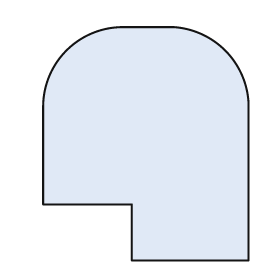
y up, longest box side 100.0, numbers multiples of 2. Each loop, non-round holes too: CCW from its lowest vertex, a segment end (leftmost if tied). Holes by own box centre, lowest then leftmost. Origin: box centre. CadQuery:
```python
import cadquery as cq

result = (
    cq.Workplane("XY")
    .moveTo(-6.0, -50.0)
    .lineTo(44.0, -50.0)
    .lineTo(44.0, 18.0)
    .threePointArc((34.0, 40.0), (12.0, 50.0))
    .lineTo(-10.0, 50.0)
    .threePointArc((-34.0, 40.0), (-44.0, 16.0))
    .lineTo(-44.0, -26.0)
    .lineTo(-6.0, -26.0)
    .close()
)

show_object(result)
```